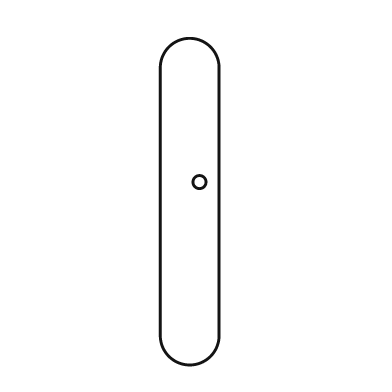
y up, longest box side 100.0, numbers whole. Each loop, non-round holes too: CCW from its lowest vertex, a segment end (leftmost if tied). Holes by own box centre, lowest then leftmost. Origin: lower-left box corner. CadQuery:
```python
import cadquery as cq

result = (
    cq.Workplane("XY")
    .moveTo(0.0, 9.0)
    .threePointArc((9.0, 0.0), (18.0, 9.0))
    .lineTo(18.0, 91.0)
    .threePointArc((9.0, 100.0), (0.0, 91.0))
    .close()
    .moveTo(12.0, 56.0)
    .circle(2.0)
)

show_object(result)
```